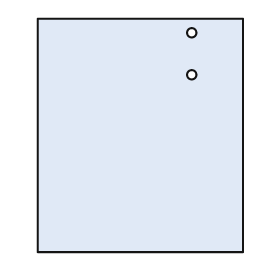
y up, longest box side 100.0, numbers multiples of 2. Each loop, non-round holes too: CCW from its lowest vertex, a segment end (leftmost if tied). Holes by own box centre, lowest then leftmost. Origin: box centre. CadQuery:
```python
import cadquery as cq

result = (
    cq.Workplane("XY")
    .moveTo(-44.0, -50.0)
    .lineTo(44.0, -50.0)
    .lineTo(44.0, 50.0)
    .lineTo(-44.0, 50.0)
    .close()
    .moveTo(22.0, 26.0)
    .circle(2.0)
    .moveTo(22.0, 44.0)
    .circle(2.0)
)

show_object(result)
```